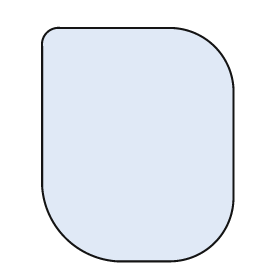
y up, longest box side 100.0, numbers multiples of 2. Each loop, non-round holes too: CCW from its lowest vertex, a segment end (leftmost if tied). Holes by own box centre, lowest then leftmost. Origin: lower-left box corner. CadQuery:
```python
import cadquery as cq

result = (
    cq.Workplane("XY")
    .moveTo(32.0, 0.0)
    .lineTo(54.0, 0.0)
    .threePointArc((74.0, 8.0), (82.0, 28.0))
    .lineTo(82.0, 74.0)
    .threePointArc((74.0, 92.0), (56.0, 100.0))
    .lineTo(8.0, 100.0)
    .threePointArc((2.0, 98.0), (0.0, 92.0))
    .lineTo(0.0, 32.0)
    .threePointArc((10.0, 10.0), (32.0, 0.0))
    .close()
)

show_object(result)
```